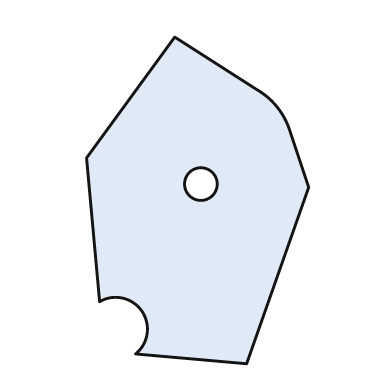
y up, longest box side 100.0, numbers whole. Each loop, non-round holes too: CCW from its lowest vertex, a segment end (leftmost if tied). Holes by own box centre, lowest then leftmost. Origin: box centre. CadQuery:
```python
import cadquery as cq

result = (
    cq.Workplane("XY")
    .moveTo(15.0, -50.0)
    .lineTo(34.0, 4.0)
    .lineTo(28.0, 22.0)
    .threePointArc((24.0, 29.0), (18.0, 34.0))
    .lineTo(-7.0, 50.0)
    .lineTo(-34.0, 13.0)
    .lineTo(-30.0, -31.0)
    .threePointArc((-17.0, -34.0), (-19.0, -47.0))
    .close()
    .moveTo(1.0, 5.0)
    .circle(5.0)
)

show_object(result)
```